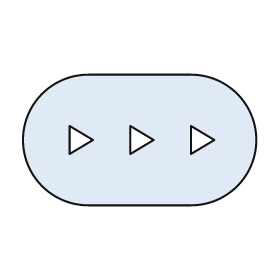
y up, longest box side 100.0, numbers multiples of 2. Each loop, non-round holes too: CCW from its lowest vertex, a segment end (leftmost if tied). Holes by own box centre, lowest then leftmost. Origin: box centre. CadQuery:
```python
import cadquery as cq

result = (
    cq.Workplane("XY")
    .moveTo(-22.0, -28.0)
    .lineTo(22.0, -28.0)
    .threePointArc((50.0, 0.0), (22.0, 28.0))
    .lineTo(-22.0, 28.0)
    .threePointArc((-50.0, 0.0), (-22.0, -28.0))
    .close()
    .moveTo(-30.0, -6.0)
    .lineTo(-20.0, 0.0)
    .lineTo(-30.0, 6.0)
    .close()
    .moveTo(-4.0, -6.0)
    .lineTo(6.0, 0.0)
    .lineTo(-4.0, 6.0)
    .close()
    .moveTo(22.0, -6.0)
    .lineTo(32.0, 0.0)
    .lineTo(22.0, 6.0)
    .close()
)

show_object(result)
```